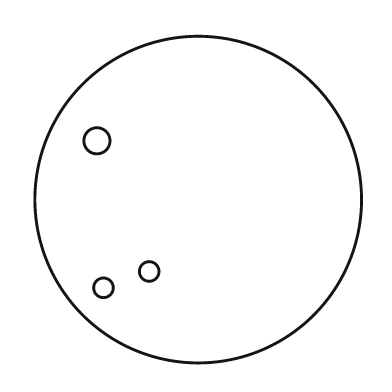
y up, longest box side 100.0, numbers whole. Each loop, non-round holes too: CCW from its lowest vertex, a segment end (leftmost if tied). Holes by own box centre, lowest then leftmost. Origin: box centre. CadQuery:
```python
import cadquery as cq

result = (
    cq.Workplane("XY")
    .moveTo(0.0, 0.0)
    .circle(50.0)
    .moveTo(-29.0, -27.0)
    .circle(3.0)
    .moveTo(-15.0, -22.0)
    .circle(3.0)
    .moveTo(-31.0, 18.0)
    .circle(4.0)
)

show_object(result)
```